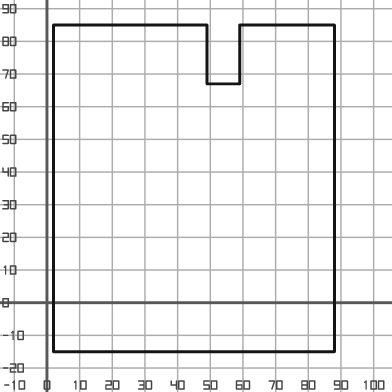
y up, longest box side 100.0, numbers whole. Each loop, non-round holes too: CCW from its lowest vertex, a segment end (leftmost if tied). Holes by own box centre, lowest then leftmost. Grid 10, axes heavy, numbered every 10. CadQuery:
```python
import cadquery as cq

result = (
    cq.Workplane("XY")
    .moveTo(2.0, -15.0)
    .lineTo(88.0, -15.0)
    .lineTo(88.0, 85.0)
    .lineTo(59.0, 85.0)
    .lineTo(59.0, 67.0)
    .lineTo(49.0, 67.0)
    .lineTo(49.0, 85.0)
    .lineTo(2.0, 85.0)
    .close()
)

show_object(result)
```